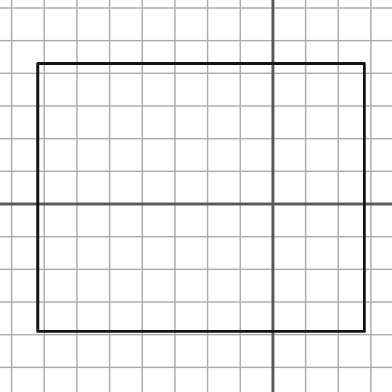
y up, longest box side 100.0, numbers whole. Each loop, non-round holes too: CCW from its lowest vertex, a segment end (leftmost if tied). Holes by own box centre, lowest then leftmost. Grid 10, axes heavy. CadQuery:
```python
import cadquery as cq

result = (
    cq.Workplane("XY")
    .moveTo(-72.0, -39.0)
    .lineTo(28.0, -39.0)
    .lineTo(28.0, 43.0)
    .lineTo(-72.0, 43.0)
    .close()
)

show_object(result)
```